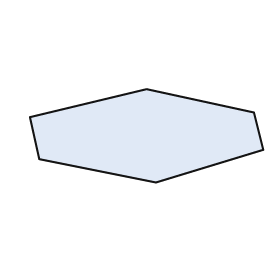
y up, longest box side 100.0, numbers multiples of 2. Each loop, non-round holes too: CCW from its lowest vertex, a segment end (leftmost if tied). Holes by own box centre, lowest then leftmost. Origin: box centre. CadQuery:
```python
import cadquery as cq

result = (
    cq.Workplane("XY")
    .moveTo(4.0, -20.0)
    .lineTo(50.0, -6.0)
    .lineTo(46.0, 10.0)
    .lineTo(0.0, 20.0)
    .lineTo(-50.0, 8.0)
    .lineTo(-46.0, -10.0)
    .close()
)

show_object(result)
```